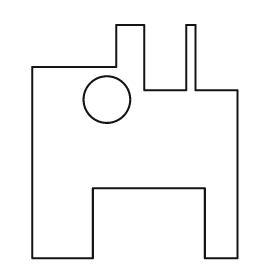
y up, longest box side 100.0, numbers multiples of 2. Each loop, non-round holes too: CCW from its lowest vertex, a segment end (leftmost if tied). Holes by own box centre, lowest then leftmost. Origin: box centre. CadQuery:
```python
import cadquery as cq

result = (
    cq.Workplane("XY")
    .moveTo(-44.0, -50.0)
    .lineTo(-18.0, -50.0)
    .lineTo(-18.0, -20.0)
    .lineTo(30.0, -20.0)
    .lineTo(30.0, -50.0)
    .lineTo(44.0, -50.0)
    .lineTo(44.0, 22.0)
    .lineTo(26.0, 22.0)
    .lineTo(26.0, 50.0)
    .lineTo(22.0, 50.0)
    .lineTo(22.0, 22.0)
    .lineTo(4.0, 22.0)
    .lineTo(4.0, 50.0)
    .lineTo(-8.0, 50.0)
    .lineTo(-8.0, 32.0)
    .lineTo(-44.0, 32.0)
    .close()
    .moveTo(-12.0, 18.0)
    .circle(10.0)
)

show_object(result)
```